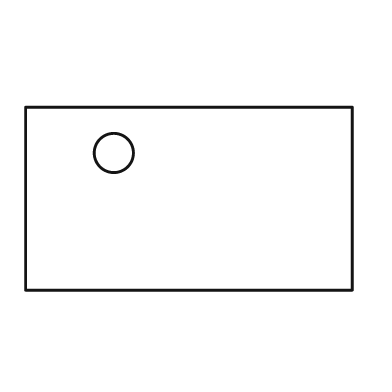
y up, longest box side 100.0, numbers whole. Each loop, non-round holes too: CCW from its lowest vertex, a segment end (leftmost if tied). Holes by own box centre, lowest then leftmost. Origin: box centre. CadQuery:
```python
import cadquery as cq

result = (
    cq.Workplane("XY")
    .moveTo(-50.0, -28.0)
    .lineTo(50.0, -28.0)
    .lineTo(50.0, 28.0)
    .lineTo(-50.0, 28.0)
    .close()
    .moveTo(-23.0, 14.0)
    .circle(6.0)
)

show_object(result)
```